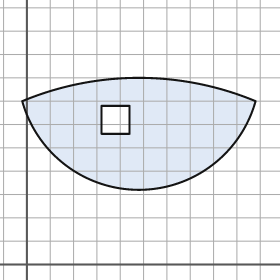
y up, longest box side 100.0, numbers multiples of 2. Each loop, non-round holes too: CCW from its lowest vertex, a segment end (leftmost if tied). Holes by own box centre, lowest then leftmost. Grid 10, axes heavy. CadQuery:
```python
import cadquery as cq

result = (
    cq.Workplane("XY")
    .moveTo(-2.0, 70.0)
    .threePointArc((48.0, 32.0), (98.0, 70.0))
    .threePointArc((48.0, 80.0), (-2.0, 70.0))
    .close()
    .moveTo(32.0, 56.0)
    .lineTo(44.0, 56.0)
    .lineTo(44.0, 68.0)
    .lineTo(32.0, 68.0)
    .close()
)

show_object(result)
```